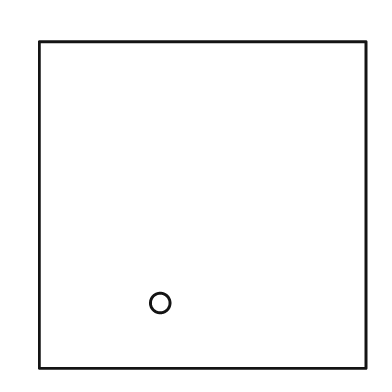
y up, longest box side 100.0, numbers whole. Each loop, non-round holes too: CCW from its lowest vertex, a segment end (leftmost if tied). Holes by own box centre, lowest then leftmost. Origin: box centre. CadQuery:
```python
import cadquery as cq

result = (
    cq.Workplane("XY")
    .moveTo(-50.0, -50.0)
    .lineTo(50.0, -50.0)
    .lineTo(50.0, 50.0)
    .lineTo(-50.0, 50.0)
    .close()
    .moveTo(-13.0, -30.0)
    .circle(3.0)
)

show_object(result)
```